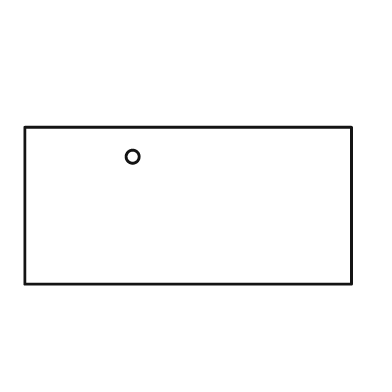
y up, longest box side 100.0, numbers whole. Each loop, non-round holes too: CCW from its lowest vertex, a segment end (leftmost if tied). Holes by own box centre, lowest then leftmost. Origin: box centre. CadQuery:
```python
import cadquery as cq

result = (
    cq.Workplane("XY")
    .moveTo(-50.0, -24.0)
    .lineTo(50.0, -24.0)
    .lineTo(50.0, 24.0)
    .lineTo(-50.0, 24.0)
    .close()
    .moveTo(-17.0, 15.0)
    .circle(2.0)
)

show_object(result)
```